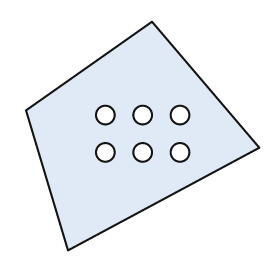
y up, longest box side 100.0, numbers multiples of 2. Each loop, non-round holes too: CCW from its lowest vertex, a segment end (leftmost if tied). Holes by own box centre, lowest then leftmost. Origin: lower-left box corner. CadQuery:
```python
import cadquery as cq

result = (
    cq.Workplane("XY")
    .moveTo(18.0, 0.0)
    .lineTo(100.0, 44.0)
    .lineTo(54.0, 98.0)
    .lineTo(0.0, 60.0)
    .close()
    .moveTo(34.0, 42.0)
    .circle(4.0)
    .moveTo(50.0, 42.0)
    .circle(4.0)
    .moveTo(66.0, 42.0)
    .circle(4.0)
    .moveTo(34.0, 58.0)
    .circle(4.0)
    .moveTo(50.0, 58.0)
    .circle(4.0)
    .moveTo(66.0, 58.0)
    .circle(4.0)
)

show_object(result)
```